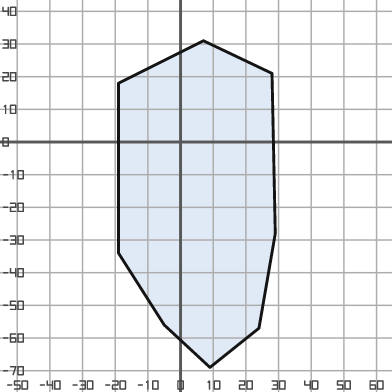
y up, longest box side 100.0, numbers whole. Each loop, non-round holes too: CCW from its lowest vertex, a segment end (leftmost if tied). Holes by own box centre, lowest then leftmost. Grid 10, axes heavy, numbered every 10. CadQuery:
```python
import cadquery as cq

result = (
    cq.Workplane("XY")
    .moveTo(9.0, -69.0)
    .lineTo(24.0, -57.0)
    .lineTo(29.0, -28.0)
    .lineTo(28.0, 21.0)
    .lineTo(7.0, 31.0)
    .lineTo(-19.0, 18.0)
    .lineTo(-19.0, -34.0)
    .lineTo(-5.0, -56.0)
    .close()
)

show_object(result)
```